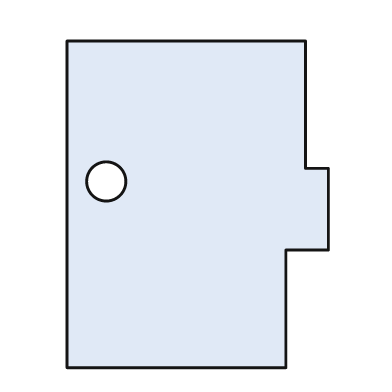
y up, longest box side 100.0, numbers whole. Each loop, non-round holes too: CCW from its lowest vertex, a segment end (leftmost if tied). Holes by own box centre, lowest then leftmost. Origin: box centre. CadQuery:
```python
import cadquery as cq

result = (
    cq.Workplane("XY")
    .moveTo(-40.0, -50.0)
    .lineTo(27.0, -50.0)
    .lineTo(27.0, -14.0)
    .lineTo(40.0, -14.0)
    .lineTo(40.0, 11.0)
    .lineTo(33.0, 11.0)
    .lineTo(33.0, 50.0)
    .lineTo(-40.0, 50.0)
    .close()
    .moveTo(-28.0, 7.0)
    .circle(6.0)
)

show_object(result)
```